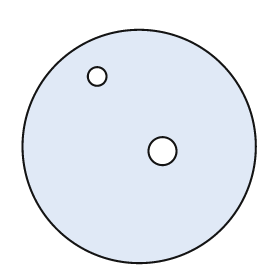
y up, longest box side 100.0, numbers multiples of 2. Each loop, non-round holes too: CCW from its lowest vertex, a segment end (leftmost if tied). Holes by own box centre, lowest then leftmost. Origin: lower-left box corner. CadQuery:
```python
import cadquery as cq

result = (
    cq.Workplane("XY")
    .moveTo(50.0, 50.0)
    .circle(50.0)
    .moveTo(60.0, 48.0)
    .circle(6.0)
    .moveTo(32.0, 80.0)
    .circle(4.0)
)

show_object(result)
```